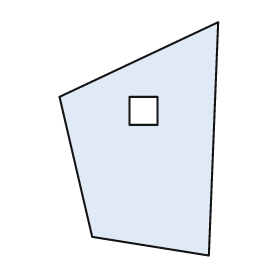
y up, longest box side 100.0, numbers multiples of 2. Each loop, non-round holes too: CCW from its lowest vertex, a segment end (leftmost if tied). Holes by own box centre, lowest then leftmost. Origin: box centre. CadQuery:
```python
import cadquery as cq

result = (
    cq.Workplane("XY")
    .moveTo(30.0, -50.0)
    .lineTo(34.0, 50.0)
    .lineTo(-34.0, 18.0)
    .lineTo(-20.0, -42.0)
    .close()
    .moveTo(-4.0, 6.0)
    .lineTo(8.0, 6.0)
    .lineTo(8.0, 18.0)
    .lineTo(-4.0, 18.0)
    .close()
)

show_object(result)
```